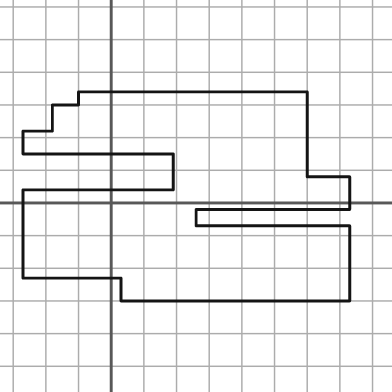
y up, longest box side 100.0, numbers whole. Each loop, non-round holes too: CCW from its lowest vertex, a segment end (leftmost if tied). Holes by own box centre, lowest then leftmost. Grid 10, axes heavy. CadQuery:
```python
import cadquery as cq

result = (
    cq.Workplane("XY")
    .moveTo(3.0, -30.0)
    .lineTo(73.0, -30.0)
    .lineTo(73.0, -7.0)
    .lineTo(26.0, -7.0)
    .lineTo(26.0, -2.0)
    .lineTo(73.0, -2.0)
    .lineTo(73.0, 8.0)
    .lineTo(60.0, 8.0)
    .lineTo(60.0, 34.0)
    .lineTo(-10.0, 34.0)
    .lineTo(-10.0, 30.0)
    .lineTo(-18.0, 30.0)
    .lineTo(-18.0, 22.0)
    .lineTo(-27.0, 22.0)
    .lineTo(-27.0, 15.0)
    .lineTo(19.0, 15.0)
    .lineTo(19.0, 4.0)
    .lineTo(-27.0, 4.0)
    .lineTo(-27.0, -23.0)
    .lineTo(3.0, -23.0)
    .close()
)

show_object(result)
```